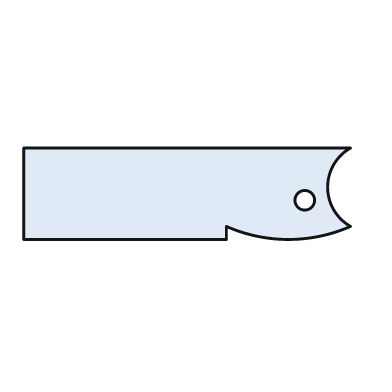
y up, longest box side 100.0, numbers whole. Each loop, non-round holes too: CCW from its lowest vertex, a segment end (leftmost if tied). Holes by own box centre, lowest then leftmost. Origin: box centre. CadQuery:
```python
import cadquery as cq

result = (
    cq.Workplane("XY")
    .moveTo(-50.0, -14.0)
    .lineTo(12.0, -14.0)
    .lineTo(12.0, -10.0)
    .threePointArc((31.0, -14.0), (50.0, -10.0))
    .threePointArc((43.0, 2.0), (50.0, 14.0))
    .lineTo(-50.0, 14.0)
    .close()
    .moveTo(36.0, -2.0)
    .circle(3.0)
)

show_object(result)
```